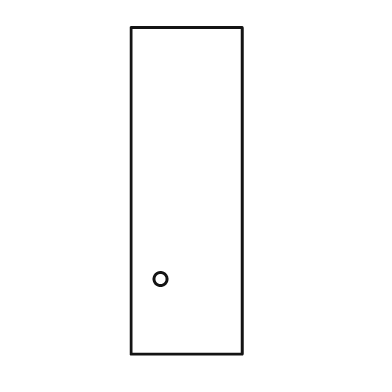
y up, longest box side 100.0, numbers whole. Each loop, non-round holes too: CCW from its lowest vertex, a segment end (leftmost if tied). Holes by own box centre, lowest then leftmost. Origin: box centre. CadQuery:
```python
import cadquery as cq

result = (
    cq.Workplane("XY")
    .moveTo(-17.0, -50.0)
    .lineTo(17.0, -50.0)
    .lineTo(17.0, 50.0)
    .lineTo(-17.0, 50.0)
    .close()
    .moveTo(-8.0, -27.0)
    .circle(2.0)
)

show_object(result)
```